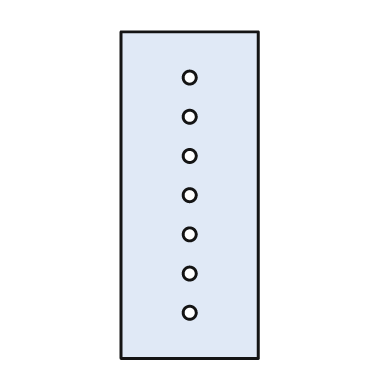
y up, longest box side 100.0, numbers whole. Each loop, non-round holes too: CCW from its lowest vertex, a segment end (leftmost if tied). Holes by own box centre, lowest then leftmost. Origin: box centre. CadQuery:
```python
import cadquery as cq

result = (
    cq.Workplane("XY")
    .moveTo(-21.0, -50.0)
    .lineTo(21.0, -50.0)
    .lineTo(21.0, 50.0)
    .lineTo(-21.0, 50.0)
    .close()
    .moveTo(0.0, -36.0)
    .circle(2.0)
    .moveTo(0.0, -24.0)
    .circle(2.0)
    .moveTo(0.0, -12.0)
    .circle(2.0)
    .moveTo(0.0, 0.0)
    .circle(2.0)
    .moveTo(0.0, 12.0)
    .circle(2.0)
    .moveTo(0.0, 24.0)
    .circle(2.0)
    .moveTo(0.0, 36.0)
    .circle(2.0)
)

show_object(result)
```